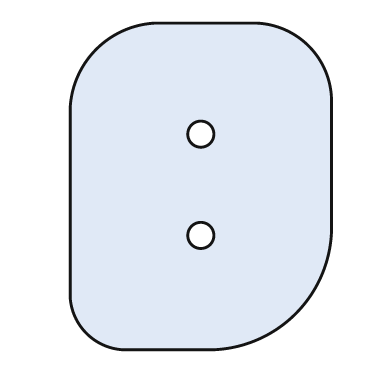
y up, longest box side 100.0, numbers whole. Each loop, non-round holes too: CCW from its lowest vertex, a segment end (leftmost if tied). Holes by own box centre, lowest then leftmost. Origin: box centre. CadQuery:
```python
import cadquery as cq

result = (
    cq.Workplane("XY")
    .moveTo(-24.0, -50.0)
    .lineTo(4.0, -50.0)
    .threePointArc((29.0, -39.0), (40.0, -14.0))
    .lineTo(40.0, 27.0)
    .threePointArc((33.0, 43.0), (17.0, 50.0))
    .lineTo(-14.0, 50.0)
    .threePointArc((-32.0, 42.0), (-40.0, 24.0))
    .lineTo(-40.0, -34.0)
    .threePointArc((-35.0, -45.0), (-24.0, -50.0))
    .close()
    .moveTo(0.0, -15.0)
    .circle(4.0)
    .moveTo(0.0, 16.0)
    .circle(4.0)
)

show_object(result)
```